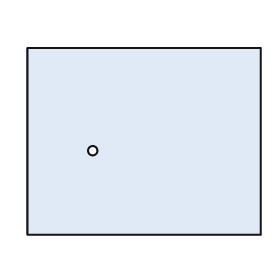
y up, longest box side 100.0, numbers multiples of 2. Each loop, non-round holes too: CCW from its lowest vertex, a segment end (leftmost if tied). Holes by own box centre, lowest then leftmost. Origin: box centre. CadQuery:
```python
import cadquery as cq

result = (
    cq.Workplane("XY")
    .moveTo(-50.0, -40.0)
    .lineTo(50.0, -40.0)
    .lineTo(50.0, 40.0)
    .lineTo(-50.0, 40.0)
    .close()
    .moveTo(-22.0, -4.0)
    .circle(2.0)
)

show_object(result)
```